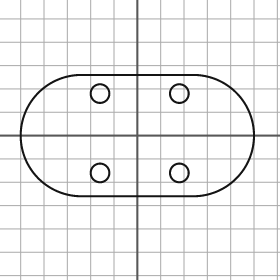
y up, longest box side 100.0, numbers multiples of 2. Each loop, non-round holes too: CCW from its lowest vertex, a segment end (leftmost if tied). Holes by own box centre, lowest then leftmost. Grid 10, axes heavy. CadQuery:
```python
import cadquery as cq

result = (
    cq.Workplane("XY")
    .moveTo(-24.0, -26.0)
    .lineTo(24.0, -26.0)
    .threePointArc((50.0, 0.0), (24.0, 26.0))
    .lineTo(-24.0, 26.0)
    .threePointArc((-50.0, 0.0), (-24.0, -26.0))
    .close()
    .moveTo(-16.0, -16.0)
    .circle(4.0)
    .moveTo(18.0, -16.0)
    .circle(4.0)
    .moveTo(-16.0, 18.0)
    .circle(4.0)
    .moveTo(18.0, 18.0)
    .circle(4.0)
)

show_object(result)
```